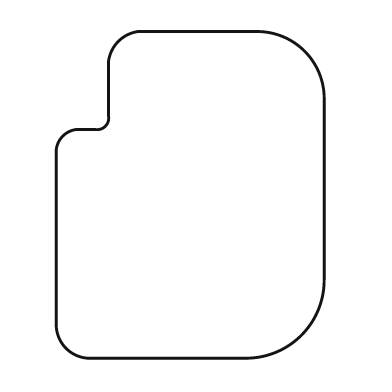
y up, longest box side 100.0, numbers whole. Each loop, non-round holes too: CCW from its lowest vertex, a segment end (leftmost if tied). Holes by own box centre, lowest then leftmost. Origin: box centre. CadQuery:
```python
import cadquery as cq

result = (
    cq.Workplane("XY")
    .moveTo(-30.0, -50.0)
    .lineTo(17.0, -50.0)
    .threePointArc((34.0, -43.0), (41.0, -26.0))
    .lineTo(41.0, 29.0)
    .threePointArc((35.0, 44.0), (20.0, 50.0))
    .lineTo(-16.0, 50.0)
    .threePointArc((-22.0, 47.0), (-25.0, 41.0))
    .lineTo(-25.0, 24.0)
    .threePointArc((-26.0, 21.0), (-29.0, 20.0))
    .lineTo(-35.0, 20.0)
    .threePointArc((-39.0, 18.0), (-41.0, 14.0))
    .lineTo(-41.0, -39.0)
    .threePointArc((-38.0, -47.0), (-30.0, -50.0))
    .close()
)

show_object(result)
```